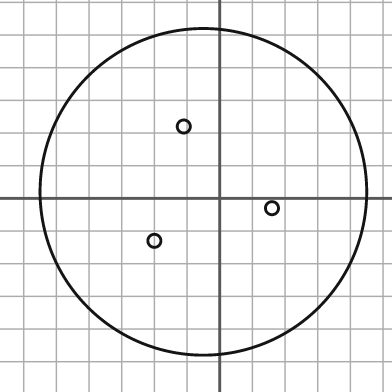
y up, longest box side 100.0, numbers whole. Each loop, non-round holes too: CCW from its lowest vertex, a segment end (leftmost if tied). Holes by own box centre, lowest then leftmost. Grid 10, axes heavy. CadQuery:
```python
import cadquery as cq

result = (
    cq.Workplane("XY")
    .moveTo(-5.0, 2.0)
    .circle(50.0)
    .moveTo(-20.0, -13.0)
    .circle(2.0)
    .moveTo(16.0, -3.0)
    .circle(2.0)
    .moveTo(-11.0, 22.0)
    .circle(2.0)
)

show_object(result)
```